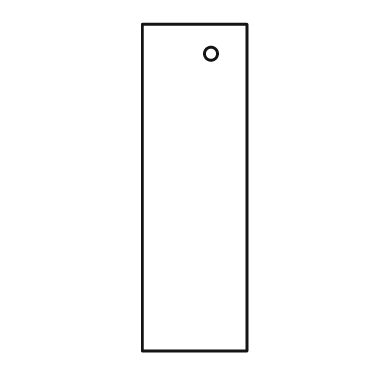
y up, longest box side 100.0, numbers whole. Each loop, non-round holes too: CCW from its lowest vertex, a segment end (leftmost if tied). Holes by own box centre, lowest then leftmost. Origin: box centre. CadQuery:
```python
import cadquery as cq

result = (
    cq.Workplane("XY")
    .moveTo(-16.0, -50.0)
    .lineTo(16.0, -50.0)
    .lineTo(16.0, 50.0)
    .lineTo(-16.0, 50.0)
    .close()
    .moveTo(5.0, 41.0)
    .circle(2.0)
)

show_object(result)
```